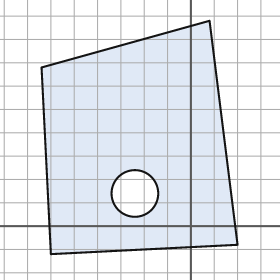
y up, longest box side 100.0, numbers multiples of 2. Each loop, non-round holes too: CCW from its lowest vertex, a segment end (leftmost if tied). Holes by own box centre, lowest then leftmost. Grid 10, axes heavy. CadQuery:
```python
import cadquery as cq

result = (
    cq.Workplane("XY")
    .moveTo(-60.0, -12.0)
    .lineTo(20.0, -8.0)
    .lineTo(8.0, 88.0)
    .lineTo(-64.0, 68.0)
    .close()
    .moveTo(-24.0, 14.0)
    .circle(10.0)
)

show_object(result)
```